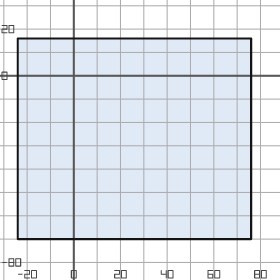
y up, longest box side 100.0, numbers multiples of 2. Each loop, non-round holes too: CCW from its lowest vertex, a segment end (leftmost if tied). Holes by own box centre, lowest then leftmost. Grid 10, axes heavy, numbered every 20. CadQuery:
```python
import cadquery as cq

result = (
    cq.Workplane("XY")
    .moveTo(-24.0, -70.0)
    .lineTo(76.0, -70.0)
    .lineTo(76.0, 16.0)
    .lineTo(-24.0, 16.0)
    .close()
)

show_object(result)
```